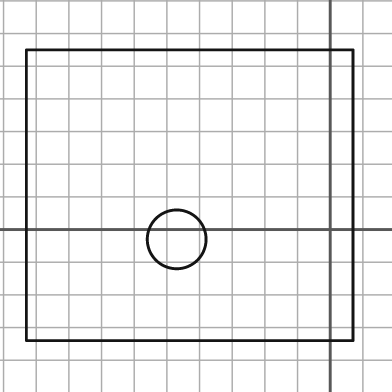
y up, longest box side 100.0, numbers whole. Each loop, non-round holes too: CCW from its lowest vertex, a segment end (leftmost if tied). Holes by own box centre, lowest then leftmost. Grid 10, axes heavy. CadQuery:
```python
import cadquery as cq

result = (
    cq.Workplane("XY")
    .moveTo(-93.0, -34.0)
    .lineTo(7.0, -34.0)
    .lineTo(7.0, 55.0)
    .lineTo(-93.0, 55.0)
    .close()
    .moveTo(-47.0, -3.0)
    .circle(9.0)
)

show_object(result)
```